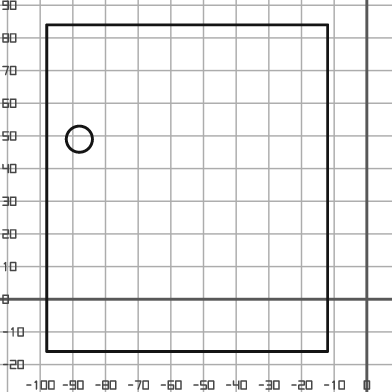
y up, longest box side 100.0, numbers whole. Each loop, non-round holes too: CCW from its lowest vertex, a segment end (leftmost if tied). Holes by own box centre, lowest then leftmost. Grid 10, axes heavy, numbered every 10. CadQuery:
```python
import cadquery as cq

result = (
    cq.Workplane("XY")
    .moveTo(-98.0, -16.0)
    .lineTo(-12.0, -16.0)
    .lineTo(-12.0, 84.0)
    .lineTo(-98.0, 84.0)
    .close()
    .moveTo(-88.0, 49.0)
    .circle(4.0)
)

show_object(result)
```